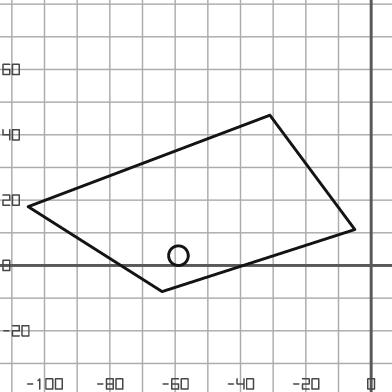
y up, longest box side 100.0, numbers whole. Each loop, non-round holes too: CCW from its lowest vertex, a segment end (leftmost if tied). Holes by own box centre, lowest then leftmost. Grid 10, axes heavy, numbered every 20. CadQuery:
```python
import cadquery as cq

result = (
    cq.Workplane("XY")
    .moveTo(-64.0, -8.0)
    .lineTo(-5.0, 11.0)
    .lineTo(-31.0, 46.0)
    .lineTo(-105.0, 18.0)
    .close()
    .moveTo(-59.0, 3.0)
    .circle(3.0)
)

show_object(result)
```